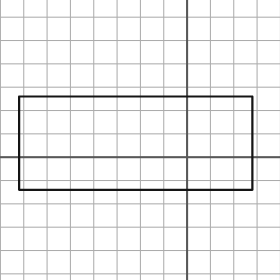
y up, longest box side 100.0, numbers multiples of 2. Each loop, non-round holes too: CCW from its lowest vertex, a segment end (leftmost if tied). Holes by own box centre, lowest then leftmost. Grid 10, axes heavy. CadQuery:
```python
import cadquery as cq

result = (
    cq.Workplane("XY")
    .moveTo(-72.0, -14.0)
    .lineTo(28.0, -14.0)
    .lineTo(28.0, 26.0)
    .lineTo(-72.0, 26.0)
    .close()
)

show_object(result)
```